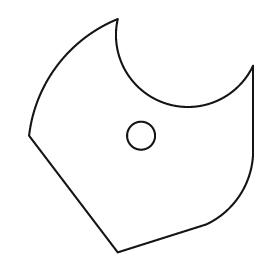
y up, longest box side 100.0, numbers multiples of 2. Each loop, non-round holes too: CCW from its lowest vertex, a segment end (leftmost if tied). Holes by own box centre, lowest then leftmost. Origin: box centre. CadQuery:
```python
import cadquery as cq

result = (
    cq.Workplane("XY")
    .moveTo(-10.0, -50.0)
    .lineTo(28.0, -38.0)
    .threePointArc((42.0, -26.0), (48.0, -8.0))
    .lineTo(48.0, 30.0)
    .threePointArc((10.0, 14.0), (-10.0, 50.0))
    .threePointArc((-36.0, 30.0), (-48.0, 0.0))
    .close()
    .moveTo(0.0, 0.0)
    .circle(6.0)
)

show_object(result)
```